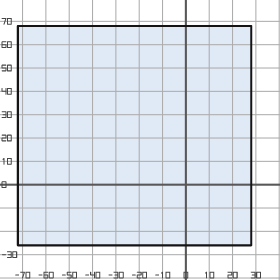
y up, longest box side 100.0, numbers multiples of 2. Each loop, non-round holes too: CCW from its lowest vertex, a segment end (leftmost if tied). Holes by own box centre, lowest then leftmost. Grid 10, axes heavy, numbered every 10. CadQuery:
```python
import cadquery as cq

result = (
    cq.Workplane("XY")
    .moveTo(-72.0, -26.0)
    .lineTo(28.0, -26.0)
    .lineTo(28.0, 68.0)
    .lineTo(-72.0, 68.0)
    .close()
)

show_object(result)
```